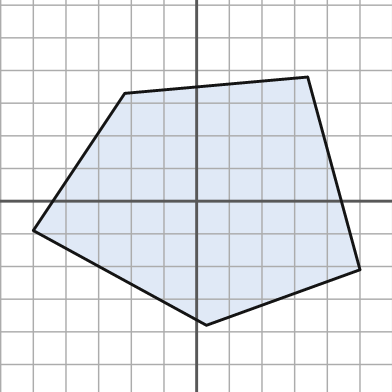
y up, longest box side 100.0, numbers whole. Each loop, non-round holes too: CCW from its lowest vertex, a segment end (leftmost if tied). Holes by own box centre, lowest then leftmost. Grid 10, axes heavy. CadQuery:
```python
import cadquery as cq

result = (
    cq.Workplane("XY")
    .moveTo(3.0, -38.0)
    .lineTo(50.0, -21.0)
    .lineTo(34.0, 38.0)
    .lineTo(-22.0, 33.0)
    .lineTo(-50.0, -9.0)
    .close()
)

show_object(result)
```